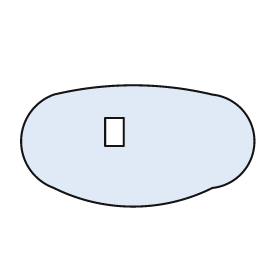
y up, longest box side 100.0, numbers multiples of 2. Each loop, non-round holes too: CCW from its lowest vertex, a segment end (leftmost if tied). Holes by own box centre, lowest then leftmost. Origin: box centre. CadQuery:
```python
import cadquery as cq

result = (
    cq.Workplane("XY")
    .moveTo(-36.0, -18.0)
    .threePointArc((-2.0, -26.0), (32.0, -18.0))
    .threePointArc((50.0, 2.0), (32.0, 22.0))
    .threePointArc((-2.0, 26.0), (-36.0, 22.0))
    .threePointArc((-50.0, 2.0), (-36.0, -18.0))
    .close()
    .moveTo(-14.0, 0.0)
    .lineTo(-6.0, 0.0)
    .lineTo(-6.0, 12.0)
    .lineTo(-14.0, 12.0)
    .close()
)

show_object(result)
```